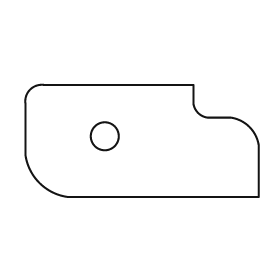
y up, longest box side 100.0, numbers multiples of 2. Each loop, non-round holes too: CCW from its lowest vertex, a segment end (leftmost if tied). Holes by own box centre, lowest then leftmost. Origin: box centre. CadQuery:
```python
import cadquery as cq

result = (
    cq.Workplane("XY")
    .moveTo(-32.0, -24.0)
    .lineTo(50.0, -24.0)
    .lineTo(50.0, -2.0)
    .threePointArc((46.0, 6.0), (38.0, 10.0))
    .lineTo(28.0, 10.0)
    .threePointArc((24.0, 12.0), (22.0, 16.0))
    .lineTo(22.0, 24.0)
    .lineTo(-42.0, 24.0)
    .threePointArc((-48.0, 22.0), (-50.0, 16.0))
    .lineTo(-50.0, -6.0)
    .threePointArc((-44.0, -18.0), (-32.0, -24.0))
    .close()
    .moveTo(-16.0, 2.0)
    .circle(6.0)
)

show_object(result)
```